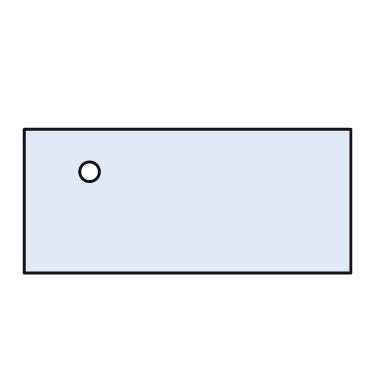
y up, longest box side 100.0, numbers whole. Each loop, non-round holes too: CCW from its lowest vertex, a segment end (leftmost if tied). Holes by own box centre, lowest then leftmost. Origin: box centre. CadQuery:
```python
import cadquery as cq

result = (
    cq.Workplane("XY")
    .moveTo(-50.0, -22.0)
    .lineTo(50.0, -22.0)
    .lineTo(50.0, 22.0)
    .lineTo(-50.0, 22.0)
    .close()
    .moveTo(-30.0, 9.0)
    .circle(3.0)
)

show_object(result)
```